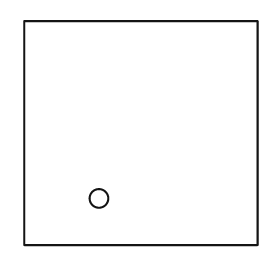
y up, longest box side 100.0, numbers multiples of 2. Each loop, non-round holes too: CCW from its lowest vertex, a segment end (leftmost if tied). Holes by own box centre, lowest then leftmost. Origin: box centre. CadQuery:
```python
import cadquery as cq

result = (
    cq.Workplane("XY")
    .moveTo(-50.0, -48.0)
    .lineTo(50.0, -48.0)
    .lineTo(50.0, 48.0)
    .lineTo(-50.0, 48.0)
    .close()
    .moveTo(-18.0, -28.0)
    .circle(4.0)
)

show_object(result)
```